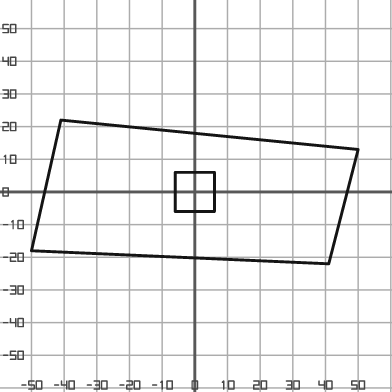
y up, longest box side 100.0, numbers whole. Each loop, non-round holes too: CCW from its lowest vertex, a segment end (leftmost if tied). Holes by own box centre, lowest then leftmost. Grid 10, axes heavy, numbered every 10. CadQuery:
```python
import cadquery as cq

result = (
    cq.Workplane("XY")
    .moveTo(41.0, -22.0)
    .lineTo(50.0, 13.0)
    .lineTo(-41.0, 22.0)
    .lineTo(-50.0, -18.0)
    .close()
    .moveTo(-6.0, -6.0)
    .lineTo(6.0, -6.0)
    .lineTo(6.0, 6.0)
    .lineTo(-6.0, 6.0)
    .close()
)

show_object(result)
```